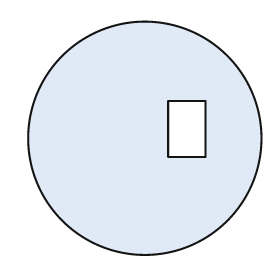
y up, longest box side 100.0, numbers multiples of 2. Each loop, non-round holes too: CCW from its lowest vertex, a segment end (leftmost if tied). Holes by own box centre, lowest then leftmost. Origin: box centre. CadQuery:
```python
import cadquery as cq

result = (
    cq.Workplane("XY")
    .moveTo(0.0, 0.0)
    .circle(50.0)
    .moveTo(10.0, -8.0)
    .lineTo(26.0, -8.0)
    .lineTo(26.0, 16.0)
    .lineTo(10.0, 16.0)
    .close()
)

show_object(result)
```